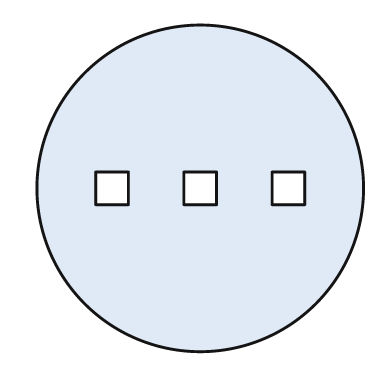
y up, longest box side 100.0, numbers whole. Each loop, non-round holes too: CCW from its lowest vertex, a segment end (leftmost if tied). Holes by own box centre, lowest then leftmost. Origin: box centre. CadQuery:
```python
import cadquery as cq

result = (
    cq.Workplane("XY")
    .moveTo(0.0, 0.0)
    .circle(50.0)
    .moveTo(-32.0, -5.0)
    .lineTo(-22.0, -5.0)
    .lineTo(-22.0, 5.0)
    .lineTo(-32.0, 5.0)
    .close()
    .moveTo(-5.0, -5.0)
    .lineTo(5.0, -5.0)
    .lineTo(5.0, 5.0)
    .lineTo(-5.0, 5.0)
    .close()
    .moveTo(22.0, -5.0)
    .lineTo(32.0, -5.0)
    .lineTo(32.0, 5.0)
    .lineTo(22.0, 5.0)
    .close()
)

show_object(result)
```